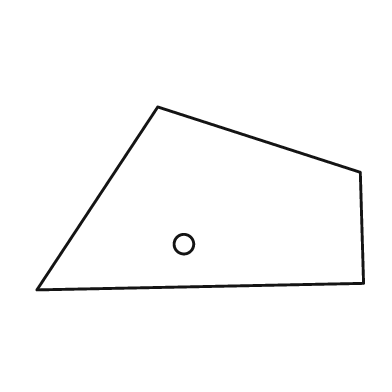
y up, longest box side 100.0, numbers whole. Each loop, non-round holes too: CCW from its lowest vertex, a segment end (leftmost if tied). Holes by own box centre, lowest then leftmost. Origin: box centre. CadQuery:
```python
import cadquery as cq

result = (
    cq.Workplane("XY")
    .moveTo(-50.0, -28.0)
    .lineTo(50.0, -26.0)
    .lineTo(49.0, 8.0)
    .lineTo(-13.0, 28.0)
    .close()
    .moveTo(-5.0, -14.0)
    .circle(3.0)
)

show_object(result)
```